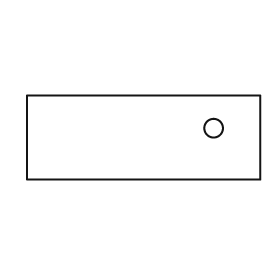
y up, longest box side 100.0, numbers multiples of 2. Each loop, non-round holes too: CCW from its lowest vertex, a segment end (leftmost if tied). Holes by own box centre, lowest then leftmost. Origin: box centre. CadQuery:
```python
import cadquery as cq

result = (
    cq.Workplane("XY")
    .moveTo(-50.0, -18.0)
    .lineTo(50.0, -18.0)
    .lineTo(50.0, 18.0)
    .lineTo(-50.0, 18.0)
    .close()
    .moveTo(30.0, 4.0)
    .circle(4.0)
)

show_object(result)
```